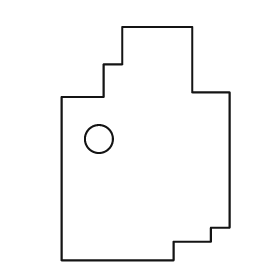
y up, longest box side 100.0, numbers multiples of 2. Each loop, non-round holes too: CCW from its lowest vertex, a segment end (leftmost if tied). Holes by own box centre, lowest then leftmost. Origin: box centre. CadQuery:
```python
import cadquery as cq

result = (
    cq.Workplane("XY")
    .moveTo(-36.0, -50.0)
    .lineTo(12.0, -50.0)
    .lineTo(12.0, -42.0)
    .lineTo(28.0, -42.0)
    .lineTo(28.0, -36.0)
    .lineTo(36.0, -36.0)
    .lineTo(36.0, 22.0)
    .lineTo(20.0, 22.0)
    .lineTo(20.0, 50.0)
    .lineTo(-10.0, 50.0)
    .lineTo(-10.0, 34.0)
    .lineTo(-18.0, 34.0)
    .lineTo(-18.0, 20.0)
    .lineTo(-36.0, 20.0)
    .close()
    .moveTo(-20.0, 2.0)
    .circle(6.0)
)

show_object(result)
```